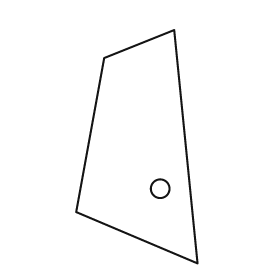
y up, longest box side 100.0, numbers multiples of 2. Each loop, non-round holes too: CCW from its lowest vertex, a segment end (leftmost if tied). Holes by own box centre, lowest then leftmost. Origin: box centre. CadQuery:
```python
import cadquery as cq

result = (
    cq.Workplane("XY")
    .moveTo(26.0, -50.0)
    .lineTo(16.0, 50.0)
    .lineTo(-14.0, 38.0)
    .lineTo(-26.0, -28.0)
    .close()
    .moveTo(10.0, -18.0)
    .circle(4.0)
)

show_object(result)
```